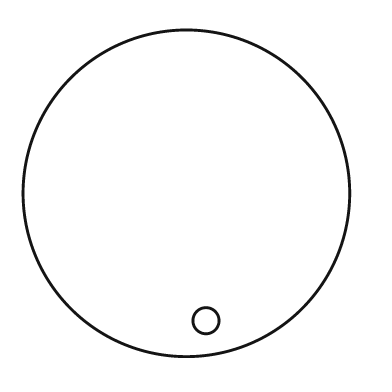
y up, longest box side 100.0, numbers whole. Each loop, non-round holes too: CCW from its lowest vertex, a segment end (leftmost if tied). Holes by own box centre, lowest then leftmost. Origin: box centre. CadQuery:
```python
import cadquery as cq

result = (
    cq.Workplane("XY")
    .moveTo(0.0, 0.0)
    .circle(50.0)
    .moveTo(6.0, -39.0)
    .circle(4.0)
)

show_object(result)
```